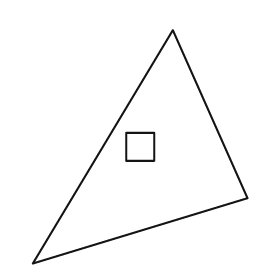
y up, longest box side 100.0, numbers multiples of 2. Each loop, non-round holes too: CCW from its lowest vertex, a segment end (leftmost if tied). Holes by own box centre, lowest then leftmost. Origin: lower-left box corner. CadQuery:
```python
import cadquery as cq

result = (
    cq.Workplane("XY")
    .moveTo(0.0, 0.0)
    .lineTo(92.0, 28.0)
    .lineTo(60.0, 100.0)
    .close()
    .moveTo(40.0, 44.0)
    .lineTo(52.0, 44.0)
    .lineTo(52.0, 56.0)
    .lineTo(40.0, 56.0)
    .close()
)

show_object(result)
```